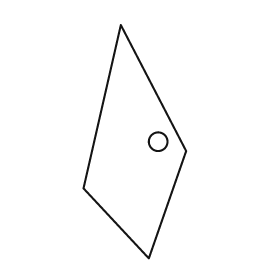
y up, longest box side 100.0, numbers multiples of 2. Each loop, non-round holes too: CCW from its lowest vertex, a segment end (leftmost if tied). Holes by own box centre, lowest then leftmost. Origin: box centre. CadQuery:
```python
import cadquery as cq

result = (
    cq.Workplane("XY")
    .moveTo(6.0, -50.0)
    .lineTo(22.0, -4.0)
    .lineTo(-6.0, 50.0)
    .lineTo(-22.0, -20.0)
    .close()
    .moveTo(10.0, 0.0)
    .circle(4.0)
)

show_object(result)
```